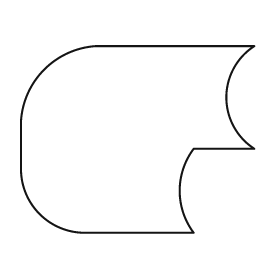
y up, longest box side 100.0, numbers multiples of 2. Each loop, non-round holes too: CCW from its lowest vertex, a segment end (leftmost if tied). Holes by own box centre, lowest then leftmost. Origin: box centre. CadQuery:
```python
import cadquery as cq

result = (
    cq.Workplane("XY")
    .moveTo(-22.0, -40.0)
    .lineTo(24.0, -40.0)
    .threePointArc((18.0, -22.0), (24.0, -4.0))
    .lineTo(50.0, -4.0)
    .threePointArc((38.0, 18.0), (50.0, 40.0))
    .lineTo(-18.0, 40.0)
    .threePointArc((-40.0, 30.0), (-50.0, 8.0))
    .lineTo(-50.0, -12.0)
    .threePointArc((-42.0, -32.0), (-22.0, -40.0))
    .close()
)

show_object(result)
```